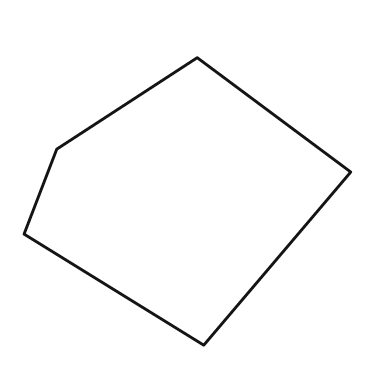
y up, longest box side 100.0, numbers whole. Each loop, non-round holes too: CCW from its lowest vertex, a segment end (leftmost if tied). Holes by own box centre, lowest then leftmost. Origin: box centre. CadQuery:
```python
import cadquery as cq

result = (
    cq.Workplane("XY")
    .moveTo(5.0, -44.0)
    .lineTo(50.0, 9.0)
    .lineTo(3.0, 44.0)
    .lineTo(-40.0, 16.0)
    .lineTo(-50.0, -10.0)
    .close()
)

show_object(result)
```